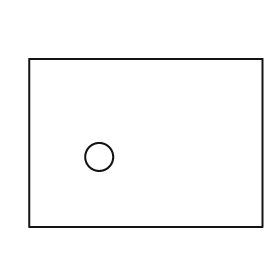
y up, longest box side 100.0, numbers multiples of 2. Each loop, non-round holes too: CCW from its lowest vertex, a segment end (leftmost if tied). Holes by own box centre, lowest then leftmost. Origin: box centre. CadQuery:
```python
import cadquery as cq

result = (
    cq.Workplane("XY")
    .moveTo(-50.0, -36.0)
    .lineTo(50.0, -36.0)
    .lineTo(50.0, 36.0)
    .lineTo(-50.0, 36.0)
    .close()
    .moveTo(-20.0, -6.0)
    .circle(6.0)
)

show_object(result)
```